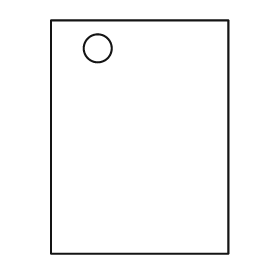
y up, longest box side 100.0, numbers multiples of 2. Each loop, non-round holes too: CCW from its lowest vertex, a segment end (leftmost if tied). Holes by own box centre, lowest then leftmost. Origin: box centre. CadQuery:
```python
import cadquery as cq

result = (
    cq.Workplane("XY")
    .moveTo(-38.0, -50.0)
    .lineTo(38.0, -50.0)
    .lineTo(38.0, 50.0)
    .lineTo(-38.0, 50.0)
    .close()
    .moveTo(-18.0, 38.0)
    .circle(6.0)
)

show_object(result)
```